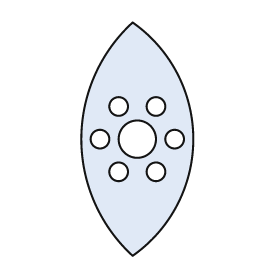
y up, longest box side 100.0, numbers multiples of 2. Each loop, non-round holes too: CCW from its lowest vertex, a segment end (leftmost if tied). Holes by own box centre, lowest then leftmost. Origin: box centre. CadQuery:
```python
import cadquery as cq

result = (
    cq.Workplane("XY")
    .moveTo(-2.0, -50.0)
    .threePointArc((24.0, 0.0), (-2.0, 50.0))
    .threePointArc((-24.0, 0.0), (-2.0, -50.0))
    .close()
    .moveTo(-8.0, -14.0)
    .circle(4.0)
    .moveTo(8.0, -14.0)
    .circle(4.0)
    .moveTo(-16.0, 0.0)
    .circle(4.0)
    .moveTo(0.0, 0.0)
    .circle(8.0)
    .moveTo(16.0, 0.0)
    .circle(4.0)
    .moveTo(-8.0, 14.0)
    .circle(4.0)
    .moveTo(8.0, 14.0)
    .circle(4.0)
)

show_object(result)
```